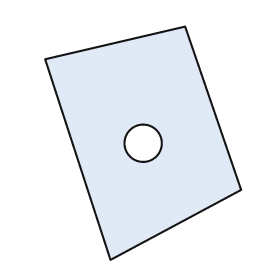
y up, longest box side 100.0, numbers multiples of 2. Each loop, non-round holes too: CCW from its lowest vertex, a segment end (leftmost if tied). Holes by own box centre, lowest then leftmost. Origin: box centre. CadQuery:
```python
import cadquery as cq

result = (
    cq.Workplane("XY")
    .moveTo(-14.0, -50.0)
    .lineTo(42.0, -20.0)
    .lineTo(18.0, 50.0)
    .lineTo(-42.0, 36.0)
    .close()
    .moveTo(0.0, 0.0)
    .circle(8.0)
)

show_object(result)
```